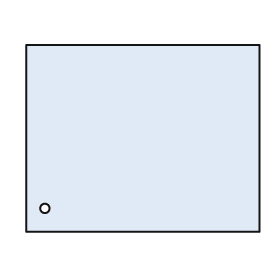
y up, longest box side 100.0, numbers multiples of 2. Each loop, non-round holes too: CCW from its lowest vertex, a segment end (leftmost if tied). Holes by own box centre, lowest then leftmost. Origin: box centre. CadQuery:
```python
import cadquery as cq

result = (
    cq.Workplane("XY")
    .moveTo(-50.0, -40.0)
    .lineTo(50.0, -40.0)
    .lineTo(50.0, 40.0)
    .lineTo(-50.0, 40.0)
    .close()
    .moveTo(-42.0, -30.0)
    .circle(2.0)
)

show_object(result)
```